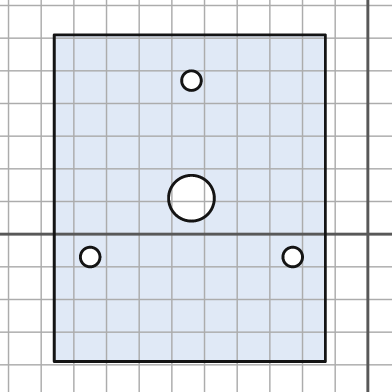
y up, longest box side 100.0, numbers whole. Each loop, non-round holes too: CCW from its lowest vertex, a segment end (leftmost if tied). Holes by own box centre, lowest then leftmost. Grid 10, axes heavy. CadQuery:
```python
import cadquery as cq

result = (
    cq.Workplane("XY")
    .moveTo(-96.0, -39.0)
    .lineTo(-13.0, -39.0)
    .lineTo(-13.0, 61.0)
    .lineTo(-96.0, 61.0)
    .close()
    .moveTo(-85.0, -7.0)
    .circle(3.0)
    .moveTo(-23.0, -7.0)
    .circle(3.0)
    .moveTo(-54.0, 11.0)
    .circle(7.0)
    .moveTo(-54.0, 47.0)
    .circle(3.0)
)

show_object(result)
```